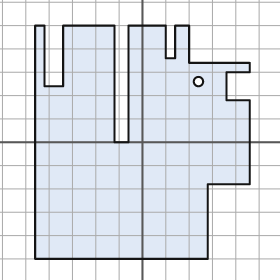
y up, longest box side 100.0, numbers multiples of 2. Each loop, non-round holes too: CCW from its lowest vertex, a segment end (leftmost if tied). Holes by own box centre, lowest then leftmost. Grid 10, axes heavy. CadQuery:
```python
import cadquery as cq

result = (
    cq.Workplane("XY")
    .moveTo(-46.0, -50.0)
    .lineTo(28.0, -50.0)
    .lineTo(28.0, -18.0)
    .lineTo(46.0, -18.0)
    .lineTo(46.0, 18.0)
    .lineTo(36.0, 18.0)
    .lineTo(36.0, 30.0)
    .lineTo(46.0, 30.0)
    .lineTo(46.0, 34.0)
    .lineTo(20.0, 34.0)
    .lineTo(20.0, 50.0)
    .lineTo(14.0, 50.0)
    .lineTo(14.0, 36.0)
    .lineTo(10.0, 36.0)
    .lineTo(10.0, 50.0)
    .lineTo(-6.0, 50.0)
    .lineTo(-6.0, 0.0)
    .lineTo(-12.0, 0.0)
    .lineTo(-12.0, 50.0)
    .lineTo(-34.0, 50.0)
    .lineTo(-34.0, 24.0)
    .lineTo(-42.0, 24.0)
    .lineTo(-42.0, 50.0)
    .lineTo(-46.0, 50.0)
    .close()
    .moveTo(24.0, 26.0)
    .circle(2.0)
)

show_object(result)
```